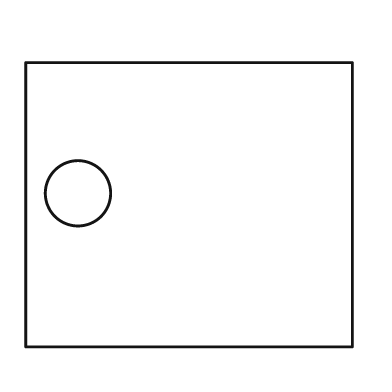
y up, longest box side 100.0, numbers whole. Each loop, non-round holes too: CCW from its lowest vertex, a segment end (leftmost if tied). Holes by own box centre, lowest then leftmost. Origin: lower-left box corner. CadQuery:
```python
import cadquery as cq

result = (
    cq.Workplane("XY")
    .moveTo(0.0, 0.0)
    .lineTo(100.0, 0.0)
    .lineTo(100.0, 87.0)
    .lineTo(0.0, 87.0)
    .close()
    .moveTo(16.0, 47.0)
    .circle(10.0)
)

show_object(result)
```